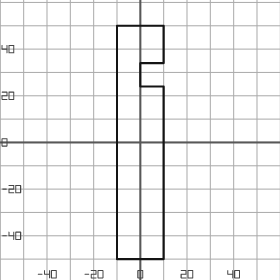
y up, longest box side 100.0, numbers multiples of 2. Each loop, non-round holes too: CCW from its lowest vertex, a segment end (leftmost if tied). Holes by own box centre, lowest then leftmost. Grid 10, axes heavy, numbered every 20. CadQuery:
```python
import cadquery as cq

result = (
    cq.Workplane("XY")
    .moveTo(-10.0, -50.0)
    .lineTo(10.0, -50.0)
    .lineTo(10.0, 24.0)
    .lineTo(0.0, 24.0)
    .lineTo(0.0, 34.0)
    .lineTo(10.0, 34.0)
    .lineTo(10.0, 50.0)
    .lineTo(-10.0, 50.0)
    .close()
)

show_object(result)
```